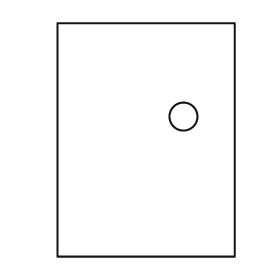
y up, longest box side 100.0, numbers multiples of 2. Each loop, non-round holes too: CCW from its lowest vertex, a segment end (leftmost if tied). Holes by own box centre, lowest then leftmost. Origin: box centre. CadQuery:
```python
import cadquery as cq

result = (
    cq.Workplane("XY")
    .moveTo(-38.0, -50.0)
    .lineTo(38.0, -50.0)
    .lineTo(38.0, 50.0)
    .lineTo(-38.0, 50.0)
    .close()
    .moveTo(16.0, 10.0)
    .circle(6.0)
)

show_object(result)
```